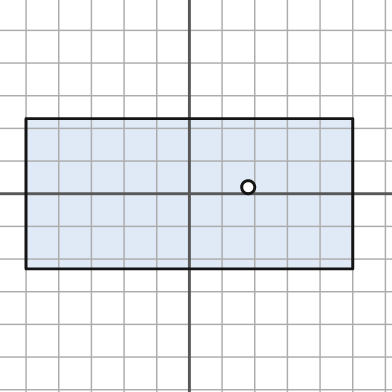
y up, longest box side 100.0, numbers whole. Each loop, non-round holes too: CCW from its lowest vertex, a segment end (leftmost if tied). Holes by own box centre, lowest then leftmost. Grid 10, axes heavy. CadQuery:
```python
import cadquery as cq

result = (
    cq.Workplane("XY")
    .moveTo(-50.0, -23.0)
    .lineTo(50.0, -23.0)
    .lineTo(50.0, 23.0)
    .lineTo(-50.0, 23.0)
    .close()
    .moveTo(18.0, 2.0)
    .circle(2.0)
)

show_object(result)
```